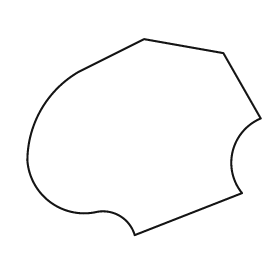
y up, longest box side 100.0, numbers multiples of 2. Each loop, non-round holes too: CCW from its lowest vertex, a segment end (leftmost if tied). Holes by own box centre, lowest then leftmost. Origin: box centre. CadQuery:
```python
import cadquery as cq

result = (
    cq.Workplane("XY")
    .moveTo(-4.0, -42.0)
    .lineTo(42.0, -24.0)
    .threePointArc((38.0, -6.0), (50.0, 8.0))
    .lineTo(34.0, 36.0)
    .lineTo(0.0, 42.0)
    .lineTo(-28.0, 28.0)
    .threePointArc((-44.0, 12.0), (-50.0, -10.0))
    .threePointArc((-40.0, -28.0), (-20.0, -32.0))
    .threePointArc((-10.0, -34.0), (-4.0, -42.0))
    .close()
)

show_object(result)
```